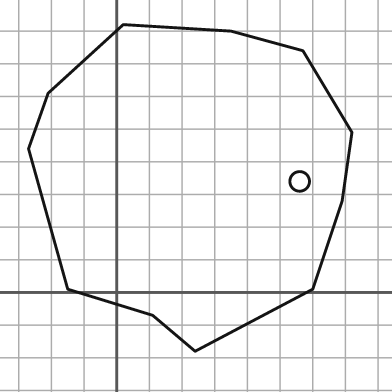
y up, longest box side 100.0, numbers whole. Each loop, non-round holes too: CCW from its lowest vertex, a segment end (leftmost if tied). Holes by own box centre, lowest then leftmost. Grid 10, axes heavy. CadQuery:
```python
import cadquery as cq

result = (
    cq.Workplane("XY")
    .moveTo(24.0, -18.0)
    .lineTo(60.0, 1.0)
    .lineTo(69.0, 28.0)
    .lineTo(72.0, 49.0)
    .lineTo(57.0, 74.0)
    .lineTo(35.0, 80.0)
    .lineTo(2.0, 82.0)
    .lineTo(-21.0, 61.0)
    .lineTo(-27.0, 44.0)
    .lineTo(-15.0, 1.0)
    .lineTo(11.0, -7.0)
    .close()
    .moveTo(56.0, 34.0)
    .circle(3.0)
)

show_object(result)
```